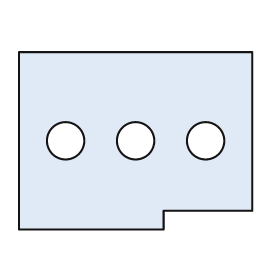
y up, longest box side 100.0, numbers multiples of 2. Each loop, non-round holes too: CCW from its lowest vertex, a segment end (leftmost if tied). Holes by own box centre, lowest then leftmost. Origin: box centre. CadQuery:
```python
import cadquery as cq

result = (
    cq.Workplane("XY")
    .moveTo(-50.0, -38.0)
    .lineTo(12.0, -38.0)
    .lineTo(12.0, -30.0)
    .lineTo(50.0, -30.0)
    .lineTo(50.0, 38.0)
    .lineTo(-50.0, 38.0)
    .close()
    .moveTo(-30.0, 0.0)
    .circle(8.0)
    .moveTo(0.0, 0.0)
    .circle(8.0)
    .moveTo(30.0, 0.0)
    .circle(8.0)
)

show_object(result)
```